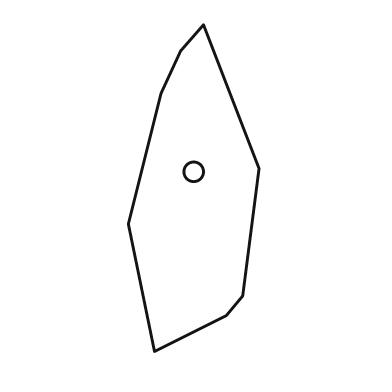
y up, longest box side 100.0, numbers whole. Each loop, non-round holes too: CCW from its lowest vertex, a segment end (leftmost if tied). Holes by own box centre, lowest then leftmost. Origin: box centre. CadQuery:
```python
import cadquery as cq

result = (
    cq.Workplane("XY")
    .moveTo(-12.0, -50.0)
    .lineTo(10.0, -39.0)
    .lineTo(15.0, -33.0)
    .lineTo(20.0, 6.0)
    .lineTo(3.0, 50.0)
    .lineTo(-4.0, 42.0)
    .lineTo(-10.0, 29.0)
    .lineTo(-20.0, -11.0)
    .close()
    .moveTo(0.0, 5.0)
    .circle(3.0)
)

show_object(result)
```